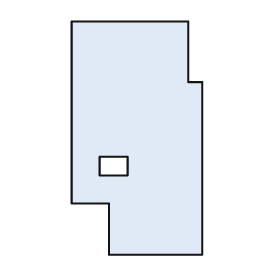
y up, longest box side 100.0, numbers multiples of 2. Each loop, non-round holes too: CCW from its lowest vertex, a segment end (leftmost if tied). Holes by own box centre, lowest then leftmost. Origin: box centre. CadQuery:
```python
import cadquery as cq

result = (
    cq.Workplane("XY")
    .moveTo(-12.0, -50.0)
    .lineTo(28.0, -50.0)
    .lineTo(28.0, 24.0)
    .lineTo(22.0, 24.0)
    .lineTo(22.0, 50.0)
    .lineTo(-28.0, 50.0)
    .lineTo(-28.0, -28.0)
    .lineTo(-12.0, -28.0)
    .close()
    .moveTo(-16.0, -16.0)
    .lineTo(-4.0, -16.0)
    .lineTo(-4.0, -8.0)
    .lineTo(-16.0, -8.0)
    .close()
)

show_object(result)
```